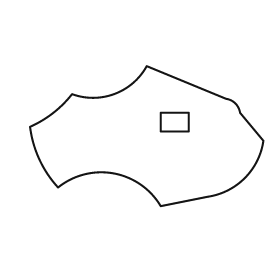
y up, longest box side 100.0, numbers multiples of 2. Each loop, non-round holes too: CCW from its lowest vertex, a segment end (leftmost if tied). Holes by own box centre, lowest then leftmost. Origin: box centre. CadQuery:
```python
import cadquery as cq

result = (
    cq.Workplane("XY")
    .moveTo(6.0, -30.0)
    .lineTo(26.0, -26.0)
    .threePointArc((42.0, -18.0), (50.0, -2.0))
    .lineTo(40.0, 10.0)
    .threePointArc((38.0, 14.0), (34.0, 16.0))
    .lineTo(0.0, 30.0)
    .threePointArc((-14.0, 18.0), (-32.0, 18.0))
    .threePointArc((-40.0, 10.0), (-50.0, 4.0))
    .threePointArc((-46.0, -10.0), (-38.0, -22.0))
    .threePointArc((-14.0, -16.0), (6.0, -30.0))
    .close()
    .moveTo(6.0, 2.0)
    .lineTo(18.0, 2.0)
    .lineTo(18.0, 10.0)
    .lineTo(6.0, 10.0)
    .close()
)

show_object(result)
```